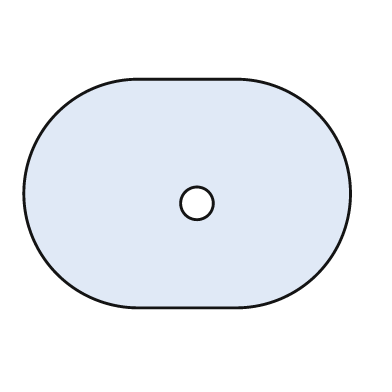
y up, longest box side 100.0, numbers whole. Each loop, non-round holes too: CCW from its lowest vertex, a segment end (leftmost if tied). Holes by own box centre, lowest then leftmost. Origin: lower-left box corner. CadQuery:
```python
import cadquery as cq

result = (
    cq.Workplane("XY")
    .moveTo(35.0, 0.0)
    .lineTo(65.0, 0.0)
    .threePointArc((100.0, 35.0), (65.0, 70.0))
    .lineTo(35.0, 70.0)
    .threePointArc((0.0, 35.0), (35.0, 0.0))
    .close()
    .moveTo(53.0, 32.0)
    .circle(5.0)
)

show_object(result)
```